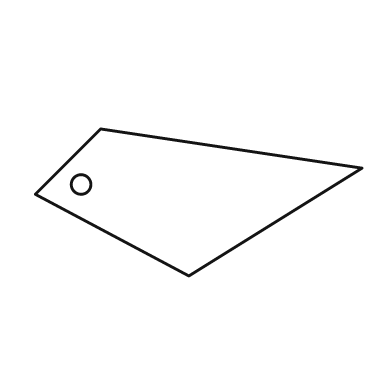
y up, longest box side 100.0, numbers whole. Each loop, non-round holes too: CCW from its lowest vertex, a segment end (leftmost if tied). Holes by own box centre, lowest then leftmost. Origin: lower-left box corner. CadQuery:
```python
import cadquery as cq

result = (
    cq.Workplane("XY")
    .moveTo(47.0, 0.0)
    .lineTo(100.0, 33.0)
    .lineTo(20.0, 45.0)
    .lineTo(0.0, 25.0)
    .close()
    .moveTo(14.0, 28.0)
    .circle(3.0)
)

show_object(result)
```